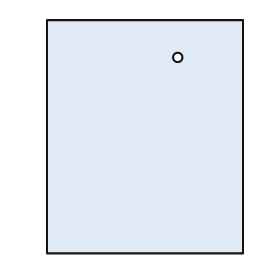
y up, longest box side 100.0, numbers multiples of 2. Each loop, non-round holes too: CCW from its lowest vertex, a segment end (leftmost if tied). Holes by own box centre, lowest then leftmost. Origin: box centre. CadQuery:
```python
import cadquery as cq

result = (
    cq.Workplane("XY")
    .moveTo(-42.0, -50.0)
    .lineTo(42.0, -50.0)
    .lineTo(42.0, 50.0)
    .lineTo(-42.0, 50.0)
    .close()
    .moveTo(14.0, 34.0)
    .circle(2.0)
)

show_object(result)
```